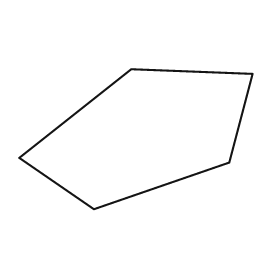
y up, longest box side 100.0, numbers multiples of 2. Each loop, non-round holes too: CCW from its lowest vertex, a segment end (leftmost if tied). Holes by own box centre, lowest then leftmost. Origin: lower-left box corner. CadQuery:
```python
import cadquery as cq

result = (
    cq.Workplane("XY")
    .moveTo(32.0, 0.0)
    .lineTo(90.0, 20.0)
    .lineTo(100.0, 58.0)
    .lineTo(48.0, 60.0)
    .lineTo(0.0, 22.0)
    .close()
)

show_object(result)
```